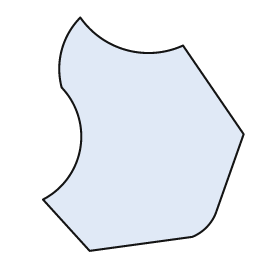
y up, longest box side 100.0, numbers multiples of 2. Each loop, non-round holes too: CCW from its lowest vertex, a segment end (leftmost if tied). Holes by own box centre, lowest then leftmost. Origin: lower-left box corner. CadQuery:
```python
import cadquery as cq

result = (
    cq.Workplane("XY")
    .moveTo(20.0, 0.0)
    .lineTo(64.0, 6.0)
    .threePointArc((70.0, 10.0), (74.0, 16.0))
    .lineTo(86.0, 50.0)
    .lineTo(60.0, 88.0)
    .threePointArc((36.0, 86.0), (16.0, 100.0))
    .threePointArc((8.0, 86.0), (8.0, 70.0))
    .threePointArc((16.0, 44.0), (0.0, 22.0))
    .close()
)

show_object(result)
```